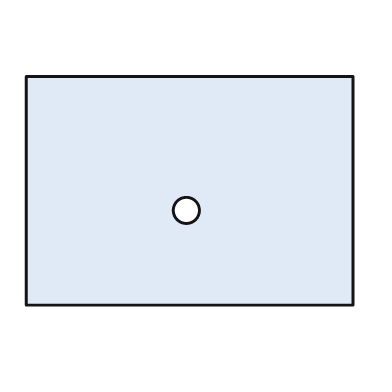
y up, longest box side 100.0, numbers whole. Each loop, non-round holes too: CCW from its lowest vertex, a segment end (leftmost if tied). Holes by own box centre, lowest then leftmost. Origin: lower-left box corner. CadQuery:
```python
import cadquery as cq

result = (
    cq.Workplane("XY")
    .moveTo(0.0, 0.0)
    .lineTo(100.0, 0.0)
    .lineTo(100.0, 70.0)
    .lineTo(0.0, 70.0)
    .close()
    .moveTo(49.0, 29.0)
    .circle(4.0)
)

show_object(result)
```